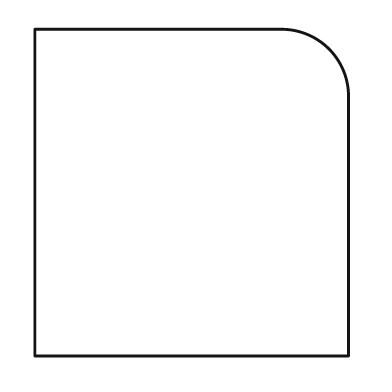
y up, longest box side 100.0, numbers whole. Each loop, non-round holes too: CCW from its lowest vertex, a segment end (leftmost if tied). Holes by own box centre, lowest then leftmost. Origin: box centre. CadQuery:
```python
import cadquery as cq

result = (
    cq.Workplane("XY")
    .moveTo(-48.0, -50.0)
    .lineTo(48.0, -50.0)
    .lineTo(48.0, 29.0)
    .threePointArc((42.0, 44.0), (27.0, 50.0))
    .lineTo(-48.0, 50.0)
    .close()
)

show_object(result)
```